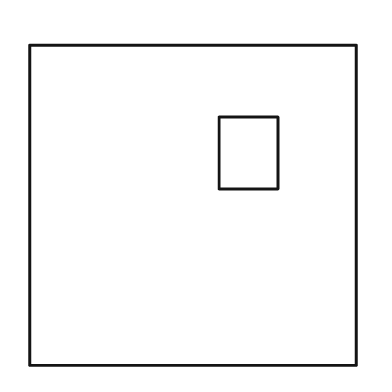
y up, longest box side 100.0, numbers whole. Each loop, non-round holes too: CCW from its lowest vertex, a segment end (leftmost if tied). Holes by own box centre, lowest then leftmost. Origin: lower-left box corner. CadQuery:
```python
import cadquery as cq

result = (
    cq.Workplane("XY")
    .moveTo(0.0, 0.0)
    .lineTo(100.0, 0.0)
    .lineTo(100.0, 98.0)
    .lineTo(0.0, 98.0)
    .close()
    .moveTo(58.0, 54.0)
    .lineTo(76.0, 54.0)
    .lineTo(76.0, 76.0)
    .lineTo(58.0, 76.0)
    .close()
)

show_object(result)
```